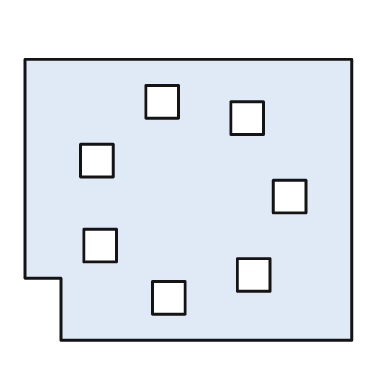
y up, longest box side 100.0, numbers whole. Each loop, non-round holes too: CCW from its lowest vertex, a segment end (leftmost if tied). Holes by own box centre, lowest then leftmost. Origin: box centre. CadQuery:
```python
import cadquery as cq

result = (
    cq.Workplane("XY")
    .moveTo(-39.0, -43.0)
    .lineTo(50.0, -43.0)
    .lineTo(50.0, 43.0)
    .lineTo(-50.0, 43.0)
    .lineTo(-50.0, -24.0)
    .lineTo(-39.0, -24.0)
    .close()
    .moveTo(-11.0, -35.0)
    .lineTo(-1.0, -35.0)
    .lineTo(-1.0, -25.0)
    .lineTo(-11.0, -25.0)
    .close()
    .moveTo(15.0, -28.0)
    .lineTo(25.0, -28.0)
    .lineTo(25.0, -18.0)
    .lineTo(15.0, -18.0)
    .close()
    .moveTo(-32.0, -19.0)
    .lineTo(-22.0, -19.0)
    .lineTo(-22.0, -9.0)
    .lineTo(-32.0, -9.0)
    .close()
    .moveTo(26.0, -4.0)
    .lineTo(36.0, -4.0)
    .lineTo(36.0, 6.0)
    .lineTo(26.0, 6.0)
    .close()
    .moveTo(-33.0, 7.0)
    .lineTo(-23.0, 7.0)
    .lineTo(-23.0, 17.0)
    .lineTo(-33.0, 17.0)
    .close()
    .moveTo(13.0, 20.0)
    .lineTo(23.0, 20.0)
    .lineTo(23.0, 30.0)
    .lineTo(13.0, 30.0)
    .close()
    .moveTo(-13.0, 25.0)
    .lineTo(-3.0, 25.0)
    .lineTo(-3.0, 35.0)
    .lineTo(-13.0, 35.0)
    .close()
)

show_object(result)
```